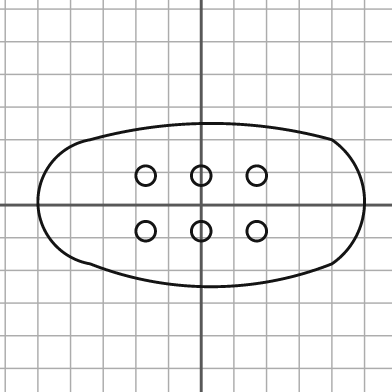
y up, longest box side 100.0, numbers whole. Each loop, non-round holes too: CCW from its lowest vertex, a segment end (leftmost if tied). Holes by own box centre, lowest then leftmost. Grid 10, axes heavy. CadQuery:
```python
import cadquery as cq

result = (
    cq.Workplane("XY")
    .moveTo(-34.0, -18.0)
    .threePointArc((3.0, -25.0), (40.0, -18.0))
    .threePointArc((50.0, 1.0), (40.0, 20.0))
    .threePointArc((3.0, 25.0), (-34.0, 20.0))
    .threePointArc((-50.0, 1.0), (-34.0, -18.0))
    .close()
    .moveTo(-17.0, -8.0)
    .circle(3.0)
    .moveTo(0.0, -8.0)
    .circle(3.0)
    .moveTo(17.0, -8.0)
    .circle(3.0)
    .moveTo(-17.0, 9.0)
    .circle(3.0)
    .moveTo(0.0, 9.0)
    .circle(3.0)
    .moveTo(17.0, 9.0)
    .circle(3.0)
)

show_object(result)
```